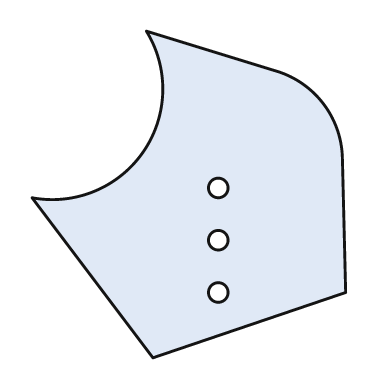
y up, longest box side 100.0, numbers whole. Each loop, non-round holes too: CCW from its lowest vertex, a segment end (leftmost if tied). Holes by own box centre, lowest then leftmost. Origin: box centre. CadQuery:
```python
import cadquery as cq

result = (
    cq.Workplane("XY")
    .moveTo(-11.0, -50.0)
    .lineTo(48.0, -30.0)
    .lineTo(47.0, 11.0)
    .threePointArc((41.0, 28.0), (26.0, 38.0))
    .lineTo(-13.0, 50.0)
    .threePointArc((-14.0, 13.0), (-48.0, -1.0))
    .close()
    .moveTo(9.0, -30.0)
    .circle(3.0)
    .moveTo(9.0, -14.0)
    .circle(3.0)
    .moveTo(9.0, 2.0)
    .circle(3.0)
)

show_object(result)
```